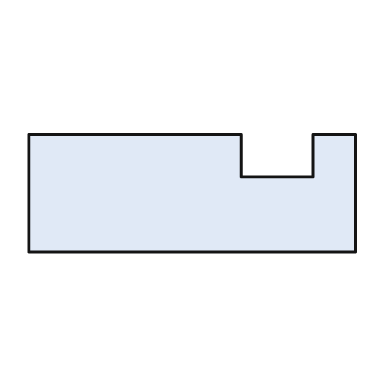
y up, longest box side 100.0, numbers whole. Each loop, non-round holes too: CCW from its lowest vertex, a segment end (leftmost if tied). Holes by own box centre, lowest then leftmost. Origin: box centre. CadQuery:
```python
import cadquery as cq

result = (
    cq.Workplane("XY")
    .moveTo(-50.0, -18.0)
    .lineTo(50.0, -18.0)
    .lineTo(50.0, 18.0)
    .lineTo(37.0, 18.0)
    .lineTo(37.0, 5.0)
    .lineTo(15.0, 5.0)
    .lineTo(15.0, 18.0)
    .lineTo(-50.0, 18.0)
    .close()
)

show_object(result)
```